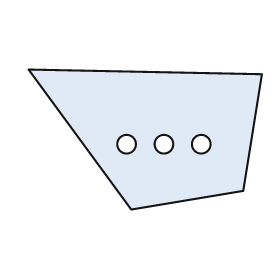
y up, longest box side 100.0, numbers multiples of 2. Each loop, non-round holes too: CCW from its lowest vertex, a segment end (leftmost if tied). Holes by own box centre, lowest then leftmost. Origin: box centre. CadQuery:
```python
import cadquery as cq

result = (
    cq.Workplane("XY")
    .moveTo(-6.0, -30.0)
    .lineTo(42.0, -22.0)
    .lineTo(50.0, 28.0)
    .lineTo(-50.0, 30.0)
    .close()
    .moveTo(-8.0, -2.0)
    .circle(4.0)
    .moveTo(8.0, -2.0)
    .circle(4.0)
    .moveTo(24.0, -2.0)
    .circle(4.0)
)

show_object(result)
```